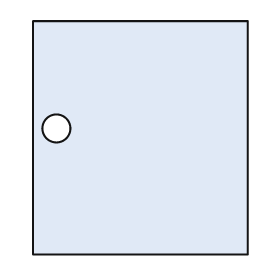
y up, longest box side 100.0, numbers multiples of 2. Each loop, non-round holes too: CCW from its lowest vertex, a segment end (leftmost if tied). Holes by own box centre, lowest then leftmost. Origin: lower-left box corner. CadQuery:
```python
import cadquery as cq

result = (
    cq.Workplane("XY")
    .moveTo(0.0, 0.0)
    .lineTo(92.0, 0.0)
    .lineTo(92.0, 100.0)
    .lineTo(0.0, 100.0)
    .close()
    .moveTo(10.0, 54.0)
    .circle(6.0)
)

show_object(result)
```